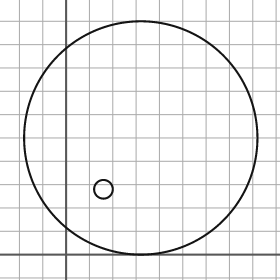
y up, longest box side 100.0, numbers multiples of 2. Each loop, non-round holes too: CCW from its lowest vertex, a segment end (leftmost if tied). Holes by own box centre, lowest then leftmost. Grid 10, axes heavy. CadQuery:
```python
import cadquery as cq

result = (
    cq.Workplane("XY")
    .moveTo(32.0, 50.0)
    .circle(50.0)
    .moveTo(16.0, 28.0)
    .circle(4.0)
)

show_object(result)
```